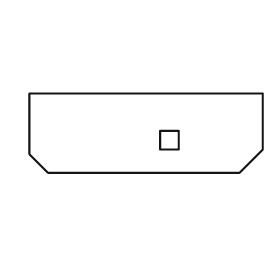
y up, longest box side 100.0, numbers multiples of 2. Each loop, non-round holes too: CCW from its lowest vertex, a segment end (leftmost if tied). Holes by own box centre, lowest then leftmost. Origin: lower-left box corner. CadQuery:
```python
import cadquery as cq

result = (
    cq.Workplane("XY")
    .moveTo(8.0, 0.0)
    .lineTo(90.0, 0.0)
    .lineTo(100.0, 10.0)
    .lineTo(100.0, 34.0)
    .lineTo(0.0, 34.0)
    .lineTo(0.0, 8.0)
    .close()
    .moveTo(56.0, 10.0)
    .lineTo(64.0, 10.0)
    .lineTo(64.0, 18.0)
    .lineTo(56.0, 18.0)
    .close()
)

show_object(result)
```